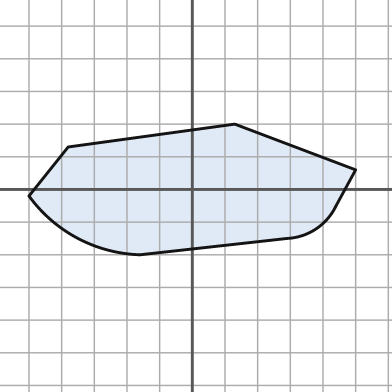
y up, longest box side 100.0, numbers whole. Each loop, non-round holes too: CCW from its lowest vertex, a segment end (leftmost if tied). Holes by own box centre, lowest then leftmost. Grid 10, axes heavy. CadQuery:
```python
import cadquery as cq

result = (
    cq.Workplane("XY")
    .moveTo(-16.0, -20.0)
    .lineTo(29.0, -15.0)
    .threePointArc((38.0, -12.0), (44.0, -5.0))
    .lineTo(50.0, 6.0)
    .lineTo(13.0, 20.0)
    .lineTo(-38.0, 13.0)
    .lineTo(-50.0, -2.0)
    .threePointArc((-35.0, -15.0), (-16.0, -20.0))
    .close()
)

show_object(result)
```